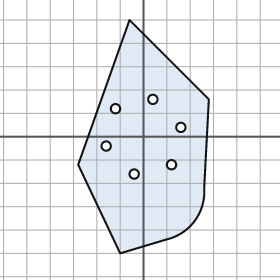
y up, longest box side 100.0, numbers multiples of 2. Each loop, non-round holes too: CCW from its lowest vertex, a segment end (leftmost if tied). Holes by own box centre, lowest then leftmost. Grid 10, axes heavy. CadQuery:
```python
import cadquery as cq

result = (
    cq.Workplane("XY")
    .moveTo(-10.0, -50.0)
    .lineTo(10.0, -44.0)
    .threePointArc((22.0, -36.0), (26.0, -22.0))
    .lineTo(28.0, 16.0)
    .lineTo(-6.0, 50.0)
    .lineTo(-28.0, -12.0)
    .close()
    .moveTo(-4.0, -16.0)
    .circle(2.0)
    .moveTo(12.0, -12.0)
    .circle(2.0)
    .moveTo(-16.0, -4.0)
    .circle(2.0)
    .moveTo(16.0, 4.0)
    .circle(2.0)
    .moveTo(-12.0, 12.0)
    .circle(2.0)
    .moveTo(4.0, 16.0)
    .circle(2.0)
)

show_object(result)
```